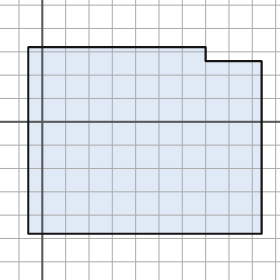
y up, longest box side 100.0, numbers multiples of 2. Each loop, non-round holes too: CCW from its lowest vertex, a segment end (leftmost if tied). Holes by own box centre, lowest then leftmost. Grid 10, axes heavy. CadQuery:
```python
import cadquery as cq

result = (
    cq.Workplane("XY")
    .moveTo(-6.0, -48.0)
    .lineTo(94.0, -48.0)
    .lineTo(94.0, 26.0)
    .lineTo(70.0, 26.0)
    .lineTo(70.0, 32.0)
    .lineTo(-6.0, 32.0)
    .close()
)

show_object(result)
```